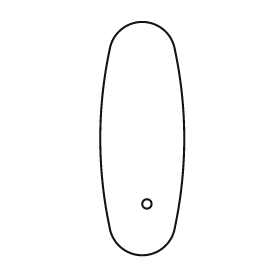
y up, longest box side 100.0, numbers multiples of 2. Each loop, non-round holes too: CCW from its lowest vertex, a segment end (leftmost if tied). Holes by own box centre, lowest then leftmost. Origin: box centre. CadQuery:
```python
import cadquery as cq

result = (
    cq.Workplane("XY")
    .moveTo(-14.0, -38.0)
    .threePointArc((0.0, -50.0), (14.0, -38.0))
    .threePointArc((18.0, 0.0), (14.0, 38.0))
    .threePointArc((0.0, 50.0), (-14.0, 38.0))
    .threePointArc((-18.0, 0.0), (-14.0, -38.0))
    .close()
    .moveTo(2.0, -28.0)
    .circle(2.0)
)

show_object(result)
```